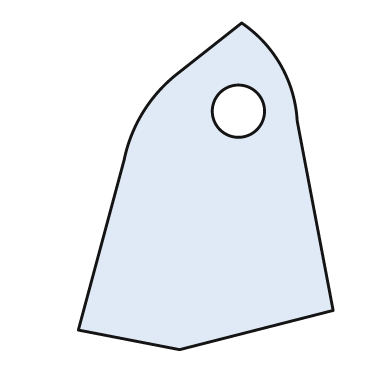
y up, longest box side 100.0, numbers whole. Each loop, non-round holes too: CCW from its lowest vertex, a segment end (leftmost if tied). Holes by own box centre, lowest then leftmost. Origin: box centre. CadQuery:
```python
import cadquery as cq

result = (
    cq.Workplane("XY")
    .moveTo(-8.0, -50.0)
    .lineTo(39.0, -38.0)
    .lineTo(28.0, 20.0)
    .threePointArc((23.0, 37.0), (11.0, 50.0))
    .lineTo(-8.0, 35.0)
    .threePointArc((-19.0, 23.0), (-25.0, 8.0))
    .lineTo(-39.0, -44.0)
    .close()
    .moveTo(10.0, 23.0)
    .circle(8.0)
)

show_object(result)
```